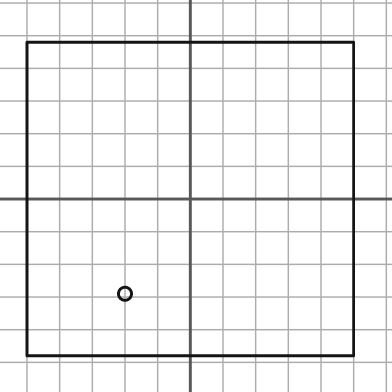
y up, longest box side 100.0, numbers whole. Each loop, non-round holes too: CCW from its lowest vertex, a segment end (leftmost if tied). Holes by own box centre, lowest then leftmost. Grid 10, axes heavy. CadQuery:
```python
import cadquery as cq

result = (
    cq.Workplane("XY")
    .moveTo(-50.0, -48.0)
    .lineTo(50.0, -48.0)
    .lineTo(50.0, 48.0)
    .lineTo(-50.0, 48.0)
    .close()
    .moveTo(-20.0, -29.0)
    .circle(2.0)
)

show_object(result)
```